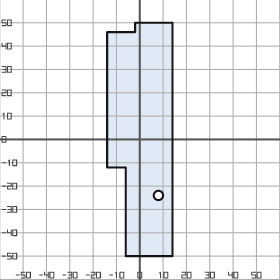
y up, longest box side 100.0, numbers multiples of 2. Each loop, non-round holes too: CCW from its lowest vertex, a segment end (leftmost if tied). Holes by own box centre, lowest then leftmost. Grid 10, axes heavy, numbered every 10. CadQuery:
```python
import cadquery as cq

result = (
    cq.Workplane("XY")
    .moveTo(-6.0, -50.0)
    .lineTo(14.0, -50.0)
    .lineTo(14.0, 50.0)
    .lineTo(-2.0, 50.0)
    .lineTo(-2.0, 46.0)
    .lineTo(-14.0, 46.0)
    .lineTo(-14.0, -12.0)
    .lineTo(-6.0, -12.0)
    .close()
    .moveTo(8.0, -24.0)
    .circle(2.0)
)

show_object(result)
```